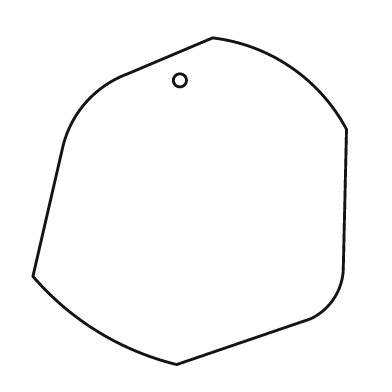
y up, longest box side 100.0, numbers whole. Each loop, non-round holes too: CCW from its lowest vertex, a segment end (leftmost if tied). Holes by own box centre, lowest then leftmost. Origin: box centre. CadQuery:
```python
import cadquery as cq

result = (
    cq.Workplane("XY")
    .moveTo(-4.0, -50.0)
    .lineTo(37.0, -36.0)
    .threePointArc((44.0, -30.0), (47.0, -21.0))
    .lineTo(48.0, 22.0)
    .threePointArc((31.0, 41.0), (7.0, 50.0))
    .lineTo(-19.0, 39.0)
    .threePointArc((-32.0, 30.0), (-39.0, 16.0))
    .lineTo(-48.0, -23.0)
    .threePointArc((-28.0, -40.0), (-4.0, -50.0))
    .close()
    .moveTo(-3.0, 37.0)
    .circle(2.0)
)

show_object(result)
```